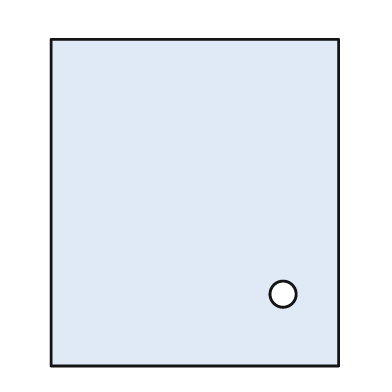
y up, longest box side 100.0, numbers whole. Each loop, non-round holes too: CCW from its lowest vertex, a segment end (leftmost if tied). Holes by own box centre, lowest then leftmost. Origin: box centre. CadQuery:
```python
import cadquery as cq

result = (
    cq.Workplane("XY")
    .moveTo(-44.0, -50.0)
    .lineTo(44.0, -50.0)
    .lineTo(44.0, 50.0)
    .lineTo(-44.0, 50.0)
    .close()
    .moveTo(27.0, -28.0)
    .circle(4.0)
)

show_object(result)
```